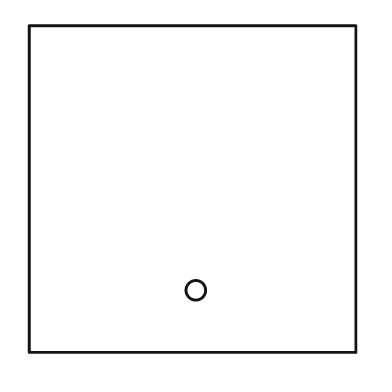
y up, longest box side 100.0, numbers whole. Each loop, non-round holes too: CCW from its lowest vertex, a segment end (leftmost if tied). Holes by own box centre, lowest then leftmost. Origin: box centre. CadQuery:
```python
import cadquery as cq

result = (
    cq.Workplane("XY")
    .moveTo(-50.0, -50.0)
    .lineTo(50.0, -50.0)
    .lineTo(50.0, 50.0)
    .lineTo(-50.0, 50.0)
    .close()
    .moveTo(1.0, -31.0)
    .circle(3.0)
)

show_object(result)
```